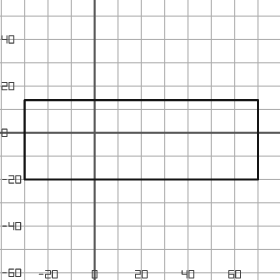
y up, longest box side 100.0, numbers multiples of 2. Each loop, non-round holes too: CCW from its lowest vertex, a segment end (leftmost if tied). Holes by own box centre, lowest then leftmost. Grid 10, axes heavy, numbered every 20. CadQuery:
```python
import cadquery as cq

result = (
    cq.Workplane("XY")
    .moveTo(-30.0, -20.0)
    .lineTo(70.0, -20.0)
    .lineTo(70.0, 14.0)
    .lineTo(-30.0, 14.0)
    .close()
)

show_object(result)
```